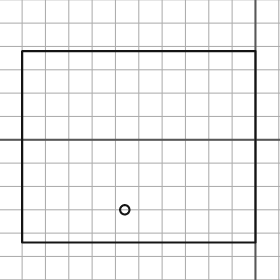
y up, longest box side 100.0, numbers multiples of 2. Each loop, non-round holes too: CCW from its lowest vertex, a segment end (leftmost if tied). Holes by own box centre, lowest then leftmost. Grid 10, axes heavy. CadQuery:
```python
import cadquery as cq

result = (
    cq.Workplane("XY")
    .moveTo(-100.0, -44.0)
    .lineTo(0.0, -44.0)
    .lineTo(0.0, 38.0)
    .lineTo(-100.0, 38.0)
    .close()
    .moveTo(-56.0, -30.0)
    .circle(2.0)
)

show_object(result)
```